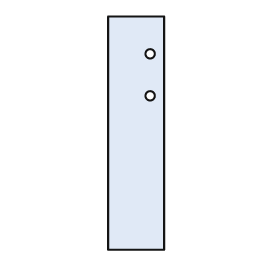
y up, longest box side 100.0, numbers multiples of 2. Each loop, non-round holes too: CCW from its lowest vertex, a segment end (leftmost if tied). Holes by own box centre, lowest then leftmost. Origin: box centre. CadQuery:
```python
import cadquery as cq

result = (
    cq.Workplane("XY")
    .moveTo(-12.0, -50.0)
    .lineTo(12.0, -50.0)
    .lineTo(12.0, 50.0)
    .lineTo(-12.0, 50.0)
    .close()
    .moveTo(6.0, 16.0)
    .circle(2.0)
    .moveTo(6.0, 34.0)
    .circle(2.0)
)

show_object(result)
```